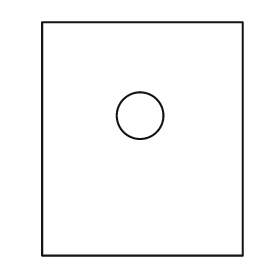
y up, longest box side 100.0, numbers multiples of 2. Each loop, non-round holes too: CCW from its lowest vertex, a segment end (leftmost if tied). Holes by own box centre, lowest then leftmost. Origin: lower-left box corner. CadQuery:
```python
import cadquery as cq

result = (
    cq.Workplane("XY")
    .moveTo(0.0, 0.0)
    .lineTo(86.0, 0.0)
    .lineTo(86.0, 100.0)
    .lineTo(0.0, 100.0)
    .close()
    .moveTo(42.0, 60.0)
    .circle(10.0)
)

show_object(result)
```